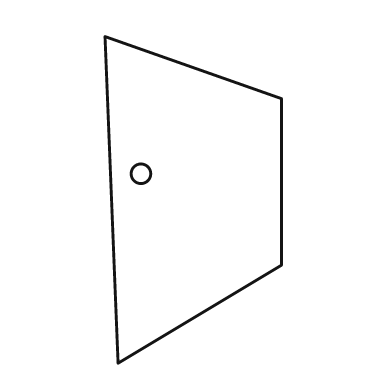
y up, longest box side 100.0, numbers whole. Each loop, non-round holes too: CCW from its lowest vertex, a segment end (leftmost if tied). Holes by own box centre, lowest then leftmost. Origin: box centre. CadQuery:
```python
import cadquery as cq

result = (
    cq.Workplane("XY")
    .moveTo(-23.0, -50.0)
    .lineTo(27.0, -20.0)
    .lineTo(27.0, 31.0)
    .lineTo(-27.0, 50.0)
    .close()
    .moveTo(-16.0, 8.0)
    .circle(3.0)
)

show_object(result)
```